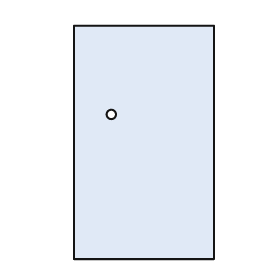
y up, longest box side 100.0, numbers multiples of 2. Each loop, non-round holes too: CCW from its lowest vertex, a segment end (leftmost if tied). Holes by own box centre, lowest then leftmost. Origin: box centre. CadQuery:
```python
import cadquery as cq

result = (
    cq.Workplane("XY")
    .moveTo(-30.0, -50.0)
    .lineTo(30.0, -50.0)
    .lineTo(30.0, 50.0)
    .lineTo(-30.0, 50.0)
    .close()
    .moveTo(-14.0, 12.0)
    .circle(2.0)
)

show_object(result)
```